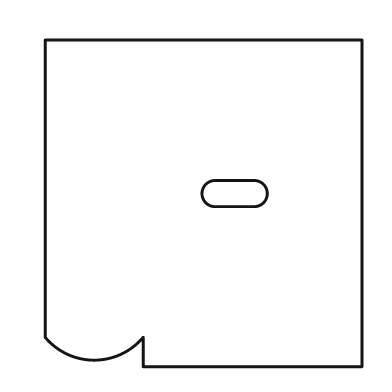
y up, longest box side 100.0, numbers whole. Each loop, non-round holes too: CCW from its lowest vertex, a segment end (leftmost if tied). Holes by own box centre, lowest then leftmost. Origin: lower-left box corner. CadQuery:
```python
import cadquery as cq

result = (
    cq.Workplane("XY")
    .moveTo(30.0, 0.0)
    .lineTo(97.0, 0.0)
    .lineTo(97.0, 100.0)
    .lineTo(0.0, 100.0)
    .lineTo(0.0, 9.0)
    .threePointArc((15.0, 2.0), (30.0, 9.0))
    .close()
    .moveTo(52.0, 49.0)
    .lineTo(64.0, 49.0)
    .threePointArc((68.0, 53.0), (64.0, 57.0))
    .lineTo(52.0, 57.0)
    .threePointArc((48.0, 53.0), (52.0, 49.0))
    .close()
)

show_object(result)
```